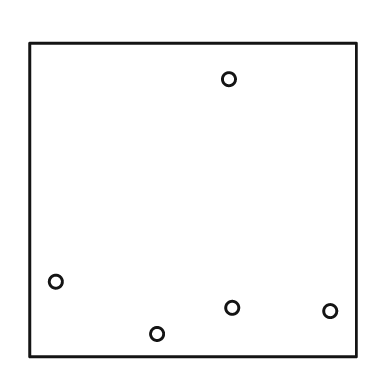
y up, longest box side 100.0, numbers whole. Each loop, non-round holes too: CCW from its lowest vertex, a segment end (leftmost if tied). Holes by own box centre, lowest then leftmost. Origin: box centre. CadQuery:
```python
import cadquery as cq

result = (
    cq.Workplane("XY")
    .moveTo(-50.0, -48.0)
    .lineTo(50.0, -48.0)
    .lineTo(50.0, 48.0)
    .lineTo(-50.0, 48.0)
    .close()
    .moveTo(-11.0, -41.0)
    .circle(2.0)
    .moveTo(42.0, -34.0)
    .circle(2.0)
    .moveTo(12.0, -33.0)
    .circle(2.0)
    .moveTo(-42.0, -25.0)
    .circle(2.0)
    .moveTo(11.0, 37.0)
    .circle(2.0)
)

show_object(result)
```